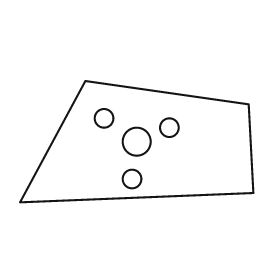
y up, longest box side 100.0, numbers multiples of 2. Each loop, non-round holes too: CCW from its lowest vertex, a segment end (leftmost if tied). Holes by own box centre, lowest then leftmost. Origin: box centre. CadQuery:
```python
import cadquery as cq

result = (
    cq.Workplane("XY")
    .moveTo(-50.0, -26.0)
    .lineTo(50.0, -22.0)
    .lineTo(48.0, 16.0)
    .lineTo(-22.0, 26.0)
    .close()
    .moveTo(-2.0, -16.0)
    .circle(4.0)
    .moveTo(0.0, 0.0)
    .circle(6.0)
    .moveTo(14.0, 6.0)
    .circle(4.0)
    .moveTo(-14.0, 10.0)
    .circle(4.0)
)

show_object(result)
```